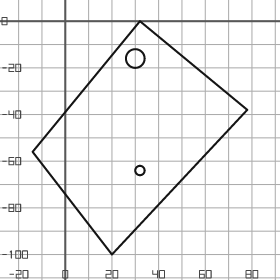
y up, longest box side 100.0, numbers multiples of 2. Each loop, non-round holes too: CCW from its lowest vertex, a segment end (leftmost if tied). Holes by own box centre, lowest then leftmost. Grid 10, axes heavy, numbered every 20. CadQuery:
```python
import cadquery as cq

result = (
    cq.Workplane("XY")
    .moveTo(20.0, -100.0)
    .lineTo(78.0, -38.0)
    .lineTo(32.0, 0.0)
    .lineTo(-14.0, -56.0)
    .close()
    .moveTo(32.0, -64.0)
    .circle(2.0)
    .moveTo(30.0, -16.0)
    .circle(4.0)
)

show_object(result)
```